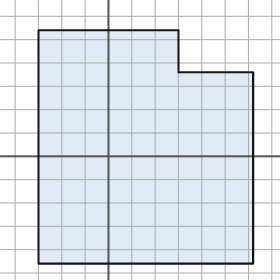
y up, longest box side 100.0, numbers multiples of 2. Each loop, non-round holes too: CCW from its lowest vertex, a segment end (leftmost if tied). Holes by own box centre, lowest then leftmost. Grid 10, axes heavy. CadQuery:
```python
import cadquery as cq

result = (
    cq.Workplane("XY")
    .moveTo(-30.0, -46.0)
    .lineTo(62.0, -46.0)
    .lineTo(62.0, 36.0)
    .lineTo(30.0, 36.0)
    .lineTo(30.0, 54.0)
    .lineTo(-30.0, 54.0)
    .close()
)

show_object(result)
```